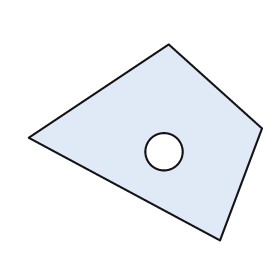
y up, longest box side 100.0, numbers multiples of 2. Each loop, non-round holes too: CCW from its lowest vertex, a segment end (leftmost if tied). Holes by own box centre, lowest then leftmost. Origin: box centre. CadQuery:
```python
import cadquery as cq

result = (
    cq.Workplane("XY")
    .moveTo(32.0, -42.0)
    .lineTo(50.0, 6.0)
    .lineTo(10.0, 42.0)
    .lineTo(-50.0, 2.0)
    .close()
    .moveTo(8.0, -4.0)
    .circle(8.0)
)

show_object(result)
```